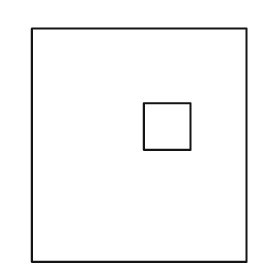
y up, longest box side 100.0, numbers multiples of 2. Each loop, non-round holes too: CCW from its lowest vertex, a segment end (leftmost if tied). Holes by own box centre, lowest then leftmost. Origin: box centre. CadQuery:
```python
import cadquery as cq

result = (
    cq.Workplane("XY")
    .moveTo(-46.0, -50.0)
    .lineTo(46.0, -50.0)
    .lineTo(46.0, 50.0)
    .lineTo(-46.0, 50.0)
    .close()
    .moveTo(2.0, -2.0)
    .lineTo(22.0, -2.0)
    .lineTo(22.0, 18.0)
    .lineTo(2.0, 18.0)
    .close()
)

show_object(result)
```